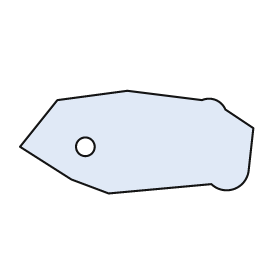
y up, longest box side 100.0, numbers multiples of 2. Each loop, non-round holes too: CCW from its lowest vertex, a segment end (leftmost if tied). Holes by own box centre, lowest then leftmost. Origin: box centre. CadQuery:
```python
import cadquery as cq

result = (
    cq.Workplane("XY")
    .moveTo(-12.0, -22.0)
    .lineTo(32.0, -18.0)
    .threePointArc((42.0, -20.0), (48.0, -12.0))
    .lineTo(50.0, 6.0)
    .lineTo(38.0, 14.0)
    .threePointArc((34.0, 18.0), (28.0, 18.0))
    .lineTo(-4.0, 22.0)
    .lineTo(-34.0, 18.0)
    .lineTo(-50.0, -2.0)
    .lineTo(-28.0, -16.0)
    .close()
    .moveTo(-22.0, -2.0)
    .circle(4.0)
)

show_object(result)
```